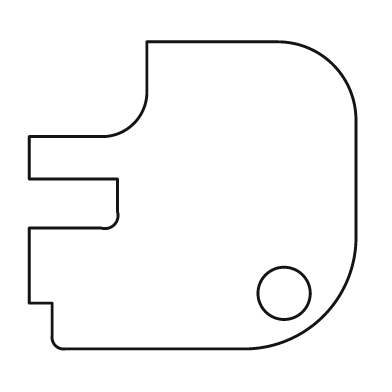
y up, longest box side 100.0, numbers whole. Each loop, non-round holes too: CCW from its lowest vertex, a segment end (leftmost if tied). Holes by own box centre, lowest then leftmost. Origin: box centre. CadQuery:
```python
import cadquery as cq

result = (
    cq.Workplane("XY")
    .moveTo(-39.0, -47.0)
    .lineTo(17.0, -47.0)
    .threePointArc((40.0, -37.0), (50.0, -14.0))
    .lineTo(50.0, 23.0)
    .threePointArc((43.0, 40.0), (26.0, 47.0))
    .lineTo(-14.0, 47.0)
    .lineTo(-14.0, 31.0)
    .threePointArc((-18.0, 22.0), (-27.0, 18.0))
    .lineTo(-50.0, 18.0)
    .lineTo(-50.0, 5.0)
    .lineTo(-23.0, 5.0)
    .lineTo(-23.0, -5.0)
    .threePointArc((-24.0, -9.0), (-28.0, -10.0))
    .lineTo(-50.0, -10.0)
    .lineTo(-50.0, -33.0)
    .lineTo(-43.0, -33.0)
    .lineTo(-43.0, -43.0)
    .threePointArc((-42.0, -46.0), (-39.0, -47.0))
    .close()
    .moveTo(28.0, -30.0)
    .circle(8.0)
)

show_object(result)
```